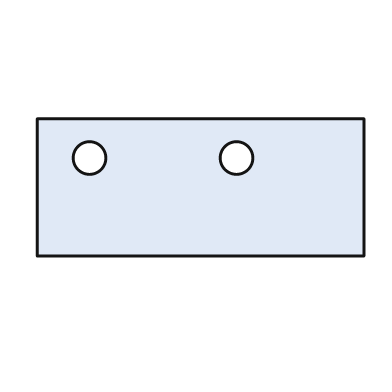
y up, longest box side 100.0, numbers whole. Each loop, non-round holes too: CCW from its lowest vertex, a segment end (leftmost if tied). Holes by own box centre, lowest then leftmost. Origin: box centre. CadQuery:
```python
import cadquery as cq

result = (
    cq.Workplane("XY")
    .moveTo(-50.0, -21.0)
    .lineTo(50.0, -21.0)
    .lineTo(50.0, 21.0)
    .lineTo(-50.0, 21.0)
    .close()
    .moveTo(-34.0, 9.0)
    .circle(5.0)
    .moveTo(11.0, 9.0)
    .circle(5.0)
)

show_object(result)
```